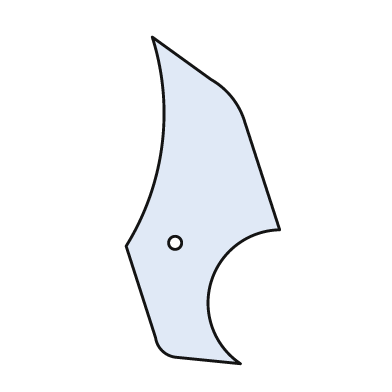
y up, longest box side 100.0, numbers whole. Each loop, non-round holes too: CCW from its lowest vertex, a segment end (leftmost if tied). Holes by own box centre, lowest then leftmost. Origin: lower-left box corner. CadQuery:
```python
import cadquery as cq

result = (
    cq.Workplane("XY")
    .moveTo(35.0, 0.0)
    .threePointArc((26.0, 25.0), (47.0, 41.0))
    .lineTo(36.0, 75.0)
    .threePointArc((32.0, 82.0), (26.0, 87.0))
    .lineTo(8.0, 100.0)
    .threePointArc((11.0, 67.0), (0.0, 36.0))
    .lineTo(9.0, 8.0)
    .threePointArc((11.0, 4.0), (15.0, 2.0))
    .close()
    .moveTo(15.0, 37.0)
    .circle(2.0)
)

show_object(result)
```